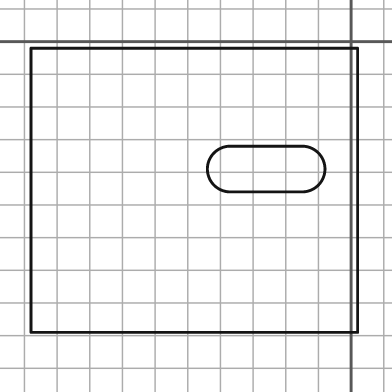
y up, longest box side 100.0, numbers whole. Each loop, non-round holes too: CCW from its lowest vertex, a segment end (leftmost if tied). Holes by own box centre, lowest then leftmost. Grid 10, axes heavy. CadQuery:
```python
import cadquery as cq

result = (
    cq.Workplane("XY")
    .moveTo(-98.0, -89.0)
    .lineTo(2.0, -89.0)
    .lineTo(2.0, -2.0)
    .lineTo(-98.0, -2.0)
    .close()
    .moveTo(-37.0, -46.0)
    .lineTo(-15.0, -46.0)
    .threePointArc((-8.0, -39.0), (-15.0, -32.0))
    .lineTo(-37.0, -32.0)
    .threePointArc((-44.0, -39.0), (-37.0, -46.0))
    .close()
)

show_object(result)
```